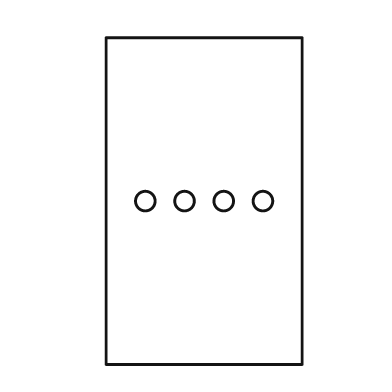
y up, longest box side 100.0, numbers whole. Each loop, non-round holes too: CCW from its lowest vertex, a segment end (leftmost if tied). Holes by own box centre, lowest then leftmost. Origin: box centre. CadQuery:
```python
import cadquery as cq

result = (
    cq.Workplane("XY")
    .moveTo(-30.0, -50.0)
    .lineTo(30.0, -50.0)
    .lineTo(30.0, 50.0)
    .lineTo(-30.0, 50.0)
    .close()
    .moveTo(-18.0, 0.0)
    .circle(3.0)
    .moveTo(-6.0, 0.0)
    .circle(3.0)
    .moveTo(6.0, 0.0)
    .circle(3.0)
    .moveTo(18.0, 0.0)
    .circle(3.0)
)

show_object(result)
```